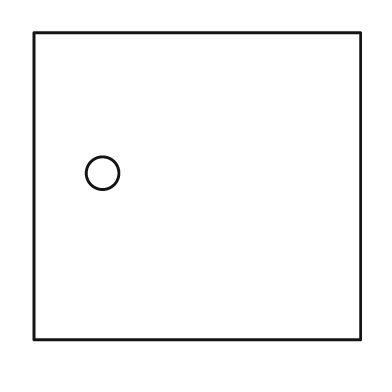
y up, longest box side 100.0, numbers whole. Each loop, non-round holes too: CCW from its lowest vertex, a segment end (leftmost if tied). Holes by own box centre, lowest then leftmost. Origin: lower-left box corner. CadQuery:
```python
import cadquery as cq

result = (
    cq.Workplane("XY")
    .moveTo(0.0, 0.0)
    .lineTo(100.0, 0.0)
    .lineTo(100.0, 94.0)
    .lineTo(0.0, 94.0)
    .close()
    .moveTo(21.0, 51.0)
    .circle(5.0)
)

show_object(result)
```